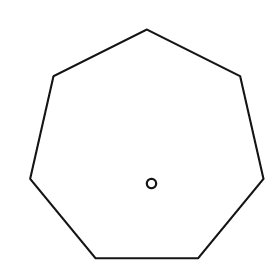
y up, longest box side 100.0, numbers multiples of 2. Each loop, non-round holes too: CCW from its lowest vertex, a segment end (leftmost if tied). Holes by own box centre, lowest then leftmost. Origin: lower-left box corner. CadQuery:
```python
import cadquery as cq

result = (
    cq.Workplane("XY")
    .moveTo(28.0, 0.0)
    .lineTo(72.0, 0.0)
    .lineTo(100.0, 34.0)
    .lineTo(90.0, 78.0)
    .lineTo(50.0, 98.0)
    .lineTo(10.0, 78.0)
    .lineTo(0.0, 34.0)
    .close()
    .moveTo(52.0, 32.0)
    .circle(2.0)
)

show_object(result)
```